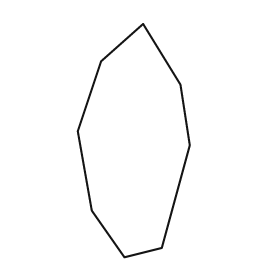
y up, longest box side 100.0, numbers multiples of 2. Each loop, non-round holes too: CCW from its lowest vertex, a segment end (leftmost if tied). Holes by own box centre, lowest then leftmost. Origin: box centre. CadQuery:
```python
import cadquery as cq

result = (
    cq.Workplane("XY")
    .moveTo(-4.0, -50.0)
    .lineTo(12.0, -46.0)
    .lineTo(24.0, -2.0)
    .lineTo(20.0, 24.0)
    .lineTo(4.0, 50.0)
    .lineTo(-14.0, 34.0)
    .lineTo(-24.0, 4.0)
    .lineTo(-18.0, -30.0)
    .close()
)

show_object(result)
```